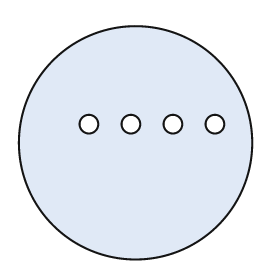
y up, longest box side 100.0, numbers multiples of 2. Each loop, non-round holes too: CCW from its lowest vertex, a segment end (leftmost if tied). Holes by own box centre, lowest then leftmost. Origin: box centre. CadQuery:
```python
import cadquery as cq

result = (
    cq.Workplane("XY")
    .moveTo(0.0, 0.0)
    .circle(50.0)
    .moveTo(-20.0, 8.0)
    .circle(4.0)
    .moveTo(-2.0, 8.0)
    .circle(4.0)
    .moveTo(16.0, 8.0)
    .circle(4.0)
    .moveTo(34.0, 8.0)
    .circle(4.0)
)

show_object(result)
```